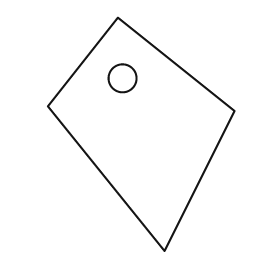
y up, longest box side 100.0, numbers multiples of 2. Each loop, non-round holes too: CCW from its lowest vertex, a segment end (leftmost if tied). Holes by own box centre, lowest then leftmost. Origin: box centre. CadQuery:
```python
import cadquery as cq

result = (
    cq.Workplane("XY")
    .moveTo(10.0, -50.0)
    .lineTo(40.0, 10.0)
    .lineTo(-10.0, 50.0)
    .lineTo(-40.0, 12.0)
    .close()
    .moveTo(-8.0, 24.0)
    .circle(6.0)
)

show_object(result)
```